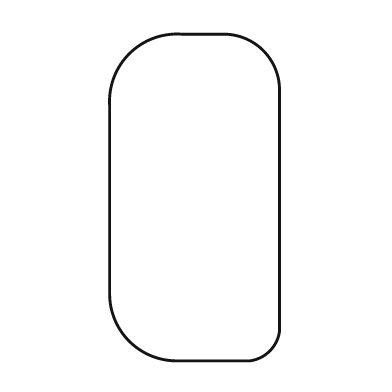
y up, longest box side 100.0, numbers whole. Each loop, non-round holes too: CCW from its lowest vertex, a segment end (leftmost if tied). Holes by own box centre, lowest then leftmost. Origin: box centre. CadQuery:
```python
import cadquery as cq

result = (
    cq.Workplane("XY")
    .moveTo(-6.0, -50.0)
    .lineTo(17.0, -50.0)
    .threePointArc((23.0, -47.0), (26.0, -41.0))
    .lineTo(26.0, 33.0)
    .threePointArc((21.0, 45.0), (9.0, 50.0))
    .lineTo(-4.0, 50.0)
    .threePointArc((-20.0, 44.0), (-26.0, 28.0))
    .lineTo(-26.0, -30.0)
    .threePointArc((-20.0, -44.0), (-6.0, -50.0))
    .close()
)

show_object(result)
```